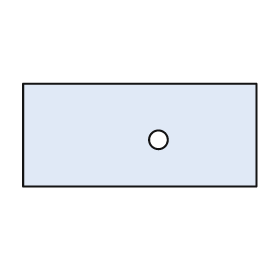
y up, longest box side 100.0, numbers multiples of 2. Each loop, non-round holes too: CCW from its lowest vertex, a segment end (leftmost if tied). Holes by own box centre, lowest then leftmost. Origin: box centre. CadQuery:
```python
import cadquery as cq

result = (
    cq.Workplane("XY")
    .moveTo(-50.0, -22.0)
    .lineTo(50.0, -22.0)
    .lineTo(50.0, 22.0)
    .lineTo(-50.0, 22.0)
    .close()
    .moveTo(8.0, -2.0)
    .circle(4.0)
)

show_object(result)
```